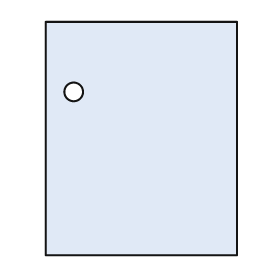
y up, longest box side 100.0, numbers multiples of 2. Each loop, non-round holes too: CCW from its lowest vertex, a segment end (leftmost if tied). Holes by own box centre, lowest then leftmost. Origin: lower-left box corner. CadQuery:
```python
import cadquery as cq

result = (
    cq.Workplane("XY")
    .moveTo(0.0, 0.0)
    .lineTo(82.0, 0.0)
    .lineTo(82.0, 100.0)
    .lineTo(0.0, 100.0)
    .close()
    .moveTo(12.0, 70.0)
    .circle(4.0)
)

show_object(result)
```